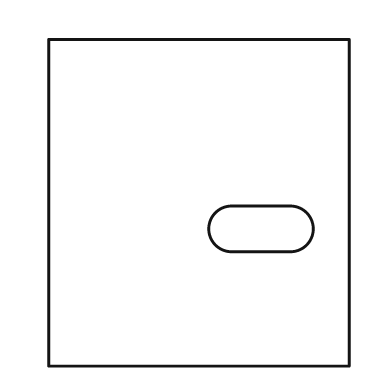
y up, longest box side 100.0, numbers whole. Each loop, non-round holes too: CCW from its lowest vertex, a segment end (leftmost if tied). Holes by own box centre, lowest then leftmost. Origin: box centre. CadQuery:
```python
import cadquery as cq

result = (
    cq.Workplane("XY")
    .moveTo(-46.0, -50.0)
    .lineTo(46.0, -50.0)
    .lineTo(46.0, 50.0)
    .lineTo(-46.0, 50.0)
    .close()
    .moveTo(10.0, -15.0)
    .lineTo(28.0, -15.0)
    .threePointArc((35.0, -8.0), (28.0, -1.0))
    .lineTo(10.0, -1.0)
    .threePointArc((3.0, -8.0), (10.0, -15.0))
    .close()
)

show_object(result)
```